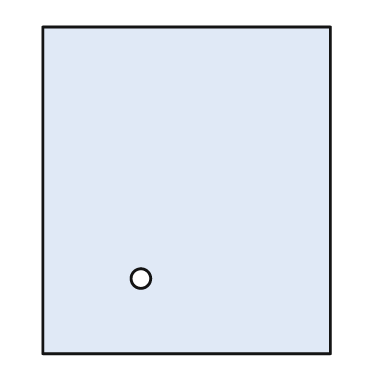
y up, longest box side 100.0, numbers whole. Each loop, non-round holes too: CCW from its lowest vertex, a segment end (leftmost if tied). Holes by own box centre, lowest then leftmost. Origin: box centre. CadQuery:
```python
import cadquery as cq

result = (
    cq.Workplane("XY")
    .moveTo(-44.0, -50.0)
    .lineTo(44.0, -50.0)
    .lineTo(44.0, 50.0)
    .lineTo(-44.0, 50.0)
    .close()
    .moveTo(-14.0, -27.0)
    .circle(3.0)
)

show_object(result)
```